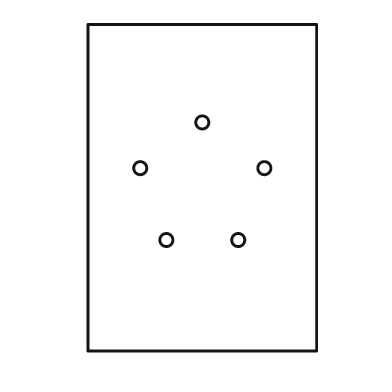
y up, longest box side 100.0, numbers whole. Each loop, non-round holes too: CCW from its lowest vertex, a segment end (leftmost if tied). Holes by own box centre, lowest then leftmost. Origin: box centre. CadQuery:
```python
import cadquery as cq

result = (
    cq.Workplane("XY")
    .moveTo(-35.0, -50.0)
    .lineTo(35.0, -50.0)
    .lineTo(35.0, 50.0)
    .lineTo(-35.0, 50.0)
    .close()
    .moveTo(-11.0, -16.0)
    .circle(2.0)
    .moveTo(11.0, -16.0)
    .circle(2.0)
    .moveTo(-19.0, 6.0)
    .circle(2.0)
    .moveTo(19.0, 6.0)
    .circle(2.0)
    .moveTo(0.0, 20.0)
    .circle(2.0)
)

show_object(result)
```